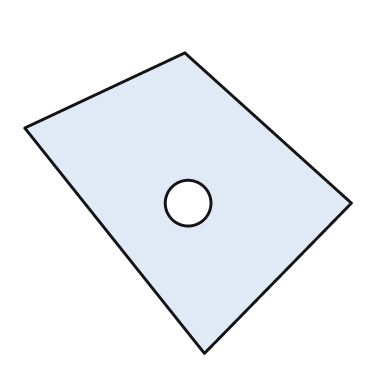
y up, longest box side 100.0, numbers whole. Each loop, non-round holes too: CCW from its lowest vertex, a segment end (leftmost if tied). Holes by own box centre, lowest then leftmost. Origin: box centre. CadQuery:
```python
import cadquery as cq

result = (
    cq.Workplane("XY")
    .moveTo(5.0, -46.0)
    .lineTo(50.0, 0.0)
    .lineTo(-1.0, 46.0)
    .lineTo(-50.0, 23.0)
    .close()
    .moveTo(0.0, 0.0)
    .circle(7.0)
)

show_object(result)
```